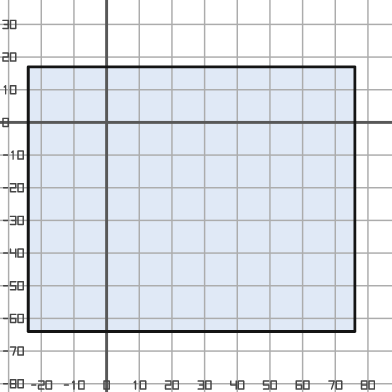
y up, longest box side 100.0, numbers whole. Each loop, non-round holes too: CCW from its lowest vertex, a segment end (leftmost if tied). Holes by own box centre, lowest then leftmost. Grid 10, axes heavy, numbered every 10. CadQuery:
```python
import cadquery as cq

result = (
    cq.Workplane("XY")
    .moveTo(-24.0, -64.0)
    .lineTo(76.0, -64.0)
    .lineTo(76.0, 17.0)
    .lineTo(-24.0, 17.0)
    .close()
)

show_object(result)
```